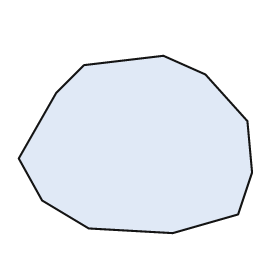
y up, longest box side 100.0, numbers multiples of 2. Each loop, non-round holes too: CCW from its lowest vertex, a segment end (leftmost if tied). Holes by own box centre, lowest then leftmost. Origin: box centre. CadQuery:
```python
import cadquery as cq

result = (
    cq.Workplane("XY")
    .moveTo(16.0, -38.0)
    .lineTo(44.0, -30.0)
    .lineTo(50.0, -12.0)
    .lineTo(48.0, 10.0)
    .lineTo(30.0, 30.0)
    .lineTo(12.0, 38.0)
    .lineTo(-22.0, 34.0)
    .lineTo(-34.0, 22.0)
    .lineTo(-50.0, -6.0)
    .lineTo(-40.0, -24.0)
    .lineTo(-20.0, -36.0)
    .close()
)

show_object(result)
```